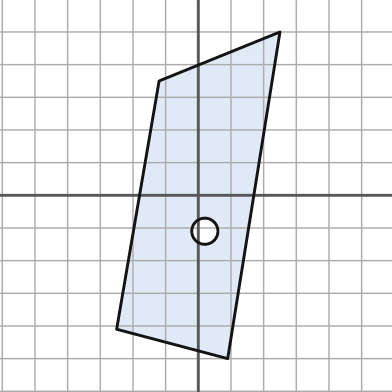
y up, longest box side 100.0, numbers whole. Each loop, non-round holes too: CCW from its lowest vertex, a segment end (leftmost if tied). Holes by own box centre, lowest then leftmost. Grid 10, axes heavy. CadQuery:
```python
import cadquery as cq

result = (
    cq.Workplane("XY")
    .moveTo(9.0, -50.0)
    .lineTo(25.0, 50.0)
    .lineTo(-12.0, 35.0)
    .lineTo(-25.0, -41.0)
    .close()
    .moveTo(2.0, -11.0)
    .circle(4.0)
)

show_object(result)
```